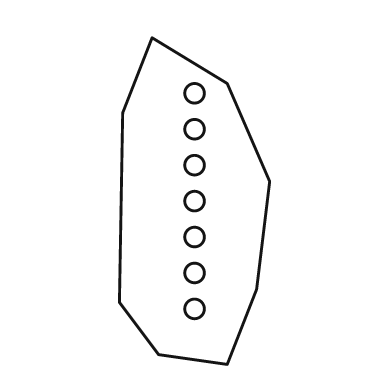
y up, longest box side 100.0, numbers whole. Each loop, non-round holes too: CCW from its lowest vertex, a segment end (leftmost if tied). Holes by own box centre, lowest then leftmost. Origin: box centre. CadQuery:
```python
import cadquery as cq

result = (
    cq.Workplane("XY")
    .moveTo(10.0, -50.0)
    .lineTo(19.0, -27.0)
    .lineTo(23.0, 6.0)
    .lineTo(10.0, 36.0)
    .lineTo(-13.0, 50.0)
    .lineTo(-22.0, 27.0)
    .lineTo(-23.0, -31.0)
    .lineTo(-11.0, -47.0)
    .close()
    .moveTo(0.0, -33.0)
    .circle(3.0)
    .moveTo(0.0, -22.0)
    .circle(3.0)
    .moveTo(0.0, -11.0)
    .circle(3.0)
    .moveTo(0.0, 0.0)
    .circle(3.0)
    .moveTo(0.0, 11.0)
    .circle(3.0)
    .moveTo(0.0, 22.0)
    .circle(3.0)
    .moveTo(0.0, 33.0)
    .circle(3.0)
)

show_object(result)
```